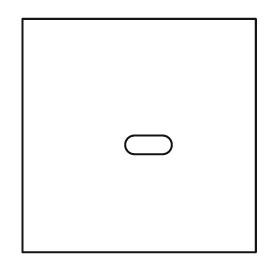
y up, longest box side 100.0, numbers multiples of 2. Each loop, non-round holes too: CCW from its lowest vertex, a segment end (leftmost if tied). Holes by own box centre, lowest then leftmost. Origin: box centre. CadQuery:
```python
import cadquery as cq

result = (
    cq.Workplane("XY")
    .moveTo(-50.0, -50.0)
    .lineTo(50.0, -50.0)
    .lineTo(50.0, 50.0)
    .lineTo(-50.0, 50.0)
    .close()
    .moveTo(-2.0, -8.0)
    .lineTo(10.0, -8.0)
    .threePointArc((14.0, -4.0), (10.0, 0.0))
    .lineTo(-2.0, 0.0)
    .threePointArc((-6.0, -4.0), (-2.0, -8.0))
    .close()
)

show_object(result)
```